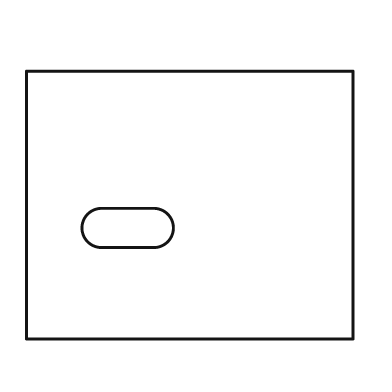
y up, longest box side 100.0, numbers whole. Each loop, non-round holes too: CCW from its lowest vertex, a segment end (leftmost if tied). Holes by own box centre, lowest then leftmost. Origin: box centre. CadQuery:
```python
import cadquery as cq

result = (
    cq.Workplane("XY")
    .moveTo(-50.0, -41.0)
    .lineTo(50.0, -41.0)
    .lineTo(50.0, 41.0)
    .lineTo(-50.0, 41.0)
    .close()
    .moveTo(-27.0, -13.0)
    .lineTo(-11.0, -13.0)
    .threePointArc((-5.0, -7.0), (-11.0, -1.0))
    .lineTo(-27.0, -1.0)
    .threePointArc((-33.0, -7.0), (-27.0, -13.0))
    .close()
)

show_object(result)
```